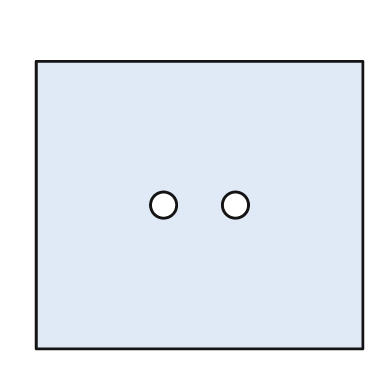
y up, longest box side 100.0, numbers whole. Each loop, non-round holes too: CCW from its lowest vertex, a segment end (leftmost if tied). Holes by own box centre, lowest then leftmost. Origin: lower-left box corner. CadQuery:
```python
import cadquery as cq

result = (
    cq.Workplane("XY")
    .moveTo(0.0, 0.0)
    .lineTo(100.0, 0.0)
    .lineTo(100.0, 88.0)
    .lineTo(0.0, 88.0)
    .close()
    .moveTo(39.0, 44.0)
    .circle(4.0)
    .moveTo(61.0, 44.0)
    .circle(4.0)
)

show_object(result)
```